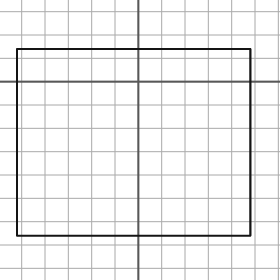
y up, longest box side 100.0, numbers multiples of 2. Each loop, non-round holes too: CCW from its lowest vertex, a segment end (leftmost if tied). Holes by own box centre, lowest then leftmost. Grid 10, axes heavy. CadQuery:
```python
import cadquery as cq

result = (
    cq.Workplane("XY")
    .moveTo(-52.0, -66.0)
    .lineTo(48.0, -66.0)
    .lineTo(48.0, 14.0)
    .lineTo(-52.0, 14.0)
    .close()
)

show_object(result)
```